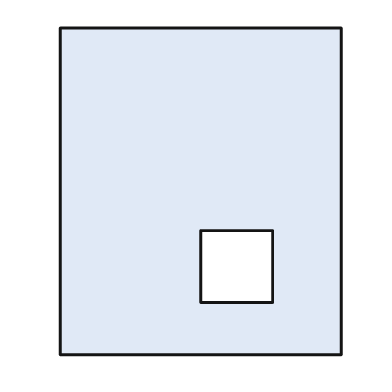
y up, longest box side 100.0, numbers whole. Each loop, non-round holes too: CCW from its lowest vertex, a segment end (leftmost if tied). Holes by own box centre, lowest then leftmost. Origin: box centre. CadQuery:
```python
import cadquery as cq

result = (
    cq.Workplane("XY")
    .moveTo(-43.0, -50.0)
    .lineTo(43.0, -50.0)
    .lineTo(43.0, 50.0)
    .lineTo(-43.0, 50.0)
    .close()
    .moveTo(0.0, -34.0)
    .lineTo(22.0, -34.0)
    .lineTo(22.0, -12.0)
    .lineTo(0.0, -12.0)
    .close()
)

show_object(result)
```